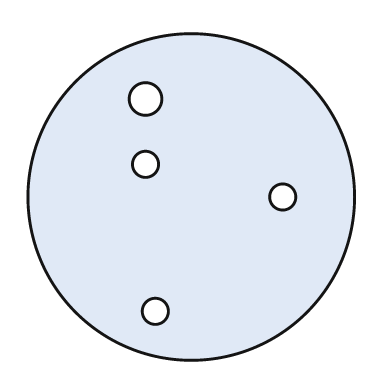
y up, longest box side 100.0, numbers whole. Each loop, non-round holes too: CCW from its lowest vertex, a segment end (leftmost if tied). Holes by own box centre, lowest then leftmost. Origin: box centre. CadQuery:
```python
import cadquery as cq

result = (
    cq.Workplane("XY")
    .moveTo(0.0, 0.0)
    .circle(50.0)
    .moveTo(-11.0, -35.0)
    .circle(4.0)
    .moveTo(28.0, 0.0)
    .circle(4.0)
    .moveTo(-14.0, 10.0)
    .circle(4.0)
    .moveTo(-14.0, 30.0)
    .circle(5.0)
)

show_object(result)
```